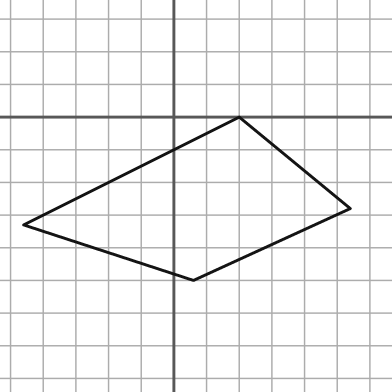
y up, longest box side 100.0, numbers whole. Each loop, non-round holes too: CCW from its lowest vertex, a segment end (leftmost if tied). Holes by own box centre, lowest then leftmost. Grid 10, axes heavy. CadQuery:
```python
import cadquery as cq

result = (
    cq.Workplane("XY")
    .moveTo(6.0, -50.0)
    .lineTo(54.0, -28.0)
    .lineTo(20.0, 0.0)
    .lineTo(-46.0, -33.0)
    .close()
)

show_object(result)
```